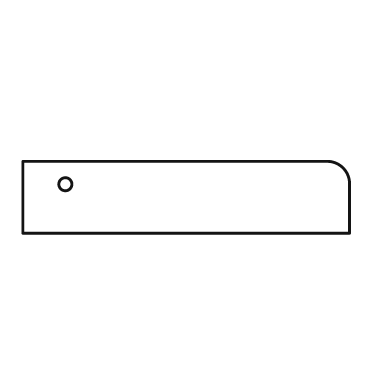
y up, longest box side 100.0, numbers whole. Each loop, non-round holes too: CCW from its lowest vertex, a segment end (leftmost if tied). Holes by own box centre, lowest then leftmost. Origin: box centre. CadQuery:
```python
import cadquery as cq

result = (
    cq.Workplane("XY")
    .moveTo(-50.0, -11.0)
    .lineTo(50.0, -11.0)
    .lineTo(50.0, 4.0)
    .threePointArc((48.0, 9.0), (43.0, 11.0))
    .lineTo(-50.0, 11.0)
    .close()
    .moveTo(-37.0, 4.0)
    .circle(2.0)
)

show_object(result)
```